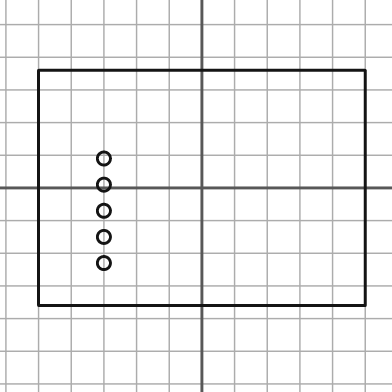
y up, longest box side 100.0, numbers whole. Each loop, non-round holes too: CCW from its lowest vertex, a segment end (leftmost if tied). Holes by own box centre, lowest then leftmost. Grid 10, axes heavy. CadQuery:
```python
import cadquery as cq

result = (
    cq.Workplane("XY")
    .moveTo(-50.0, -36.0)
    .lineTo(50.0, -36.0)
    .lineTo(50.0, 36.0)
    .lineTo(-50.0, 36.0)
    .close()
    .moveTo(-30.0, -23.0)
    .circle(2.0)
    .moveTo(-30.0, -15.0)
    .circle(2.0)
    .moveTo(-30.0, -7.0)
    .circle(2.0)
    .moveTo(-30.0, 1.0)
    .circle(2.0)
    .moveTo(-30.0, 9.0)
    .circle(2.0)
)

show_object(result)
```